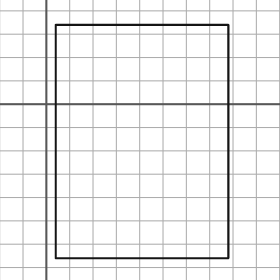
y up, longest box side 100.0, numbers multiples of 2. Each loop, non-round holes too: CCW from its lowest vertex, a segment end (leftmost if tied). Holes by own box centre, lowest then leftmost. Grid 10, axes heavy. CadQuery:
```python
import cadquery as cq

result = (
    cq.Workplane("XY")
    .moveTo(4.0, -66.0)
    .lineTo(78.0, -66.0)
    .lineTo(78.0, 34.0)
    .lineTo(4.0, 34.0)
    .close()
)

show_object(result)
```